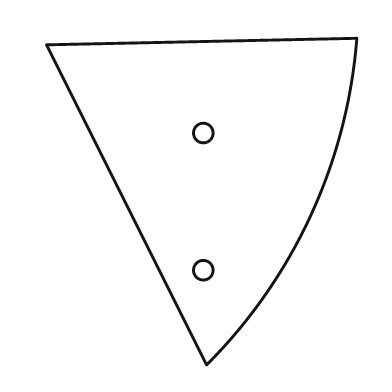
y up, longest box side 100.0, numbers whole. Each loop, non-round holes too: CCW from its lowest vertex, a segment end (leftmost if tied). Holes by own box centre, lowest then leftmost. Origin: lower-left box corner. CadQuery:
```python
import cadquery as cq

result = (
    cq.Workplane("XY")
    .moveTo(49.0, 0.0)
    .threePointArc((81.0, 46.0), (95.0, 100.0))
    .lineTo(0.0, 98.0)
    .close()
    .moveTo(48.0, 29.0)
    .circle(3.0)
    .moveTo(48.0, 71.0)
    .circle(3.0)
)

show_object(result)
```